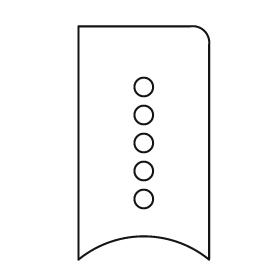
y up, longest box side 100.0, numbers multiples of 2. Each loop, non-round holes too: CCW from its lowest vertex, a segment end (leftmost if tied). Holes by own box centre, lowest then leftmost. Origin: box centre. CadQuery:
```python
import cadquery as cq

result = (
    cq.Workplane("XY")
    .moveTo(-28.0, -50.0)
    .threePointArc((0.0, -40.0), (28.0, -50.0))
    .lineTo(28.0, 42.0)
    .threePointArc((26.0, 48.0), (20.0, 50.0))
    .lineTo(-28.0, 50.0)
    .close()
    .moveTo(0.0, -24.0)
    .circle(4.0)
    .moveTo(0.0, -12.0)
    .circle(4.0)
    .moveTo(0.0, 0.0)
    .circle(4.0)
    .moveTo(0.0, 12.0)
    .circle(4.0)
    .moveTo(0.0, 24.0)
    .circle(4.0)
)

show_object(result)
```